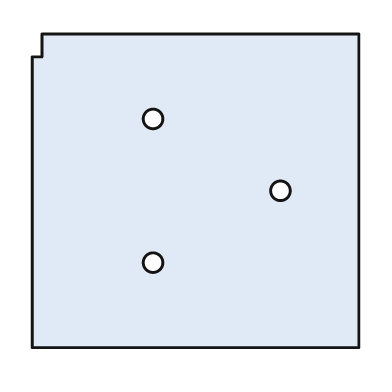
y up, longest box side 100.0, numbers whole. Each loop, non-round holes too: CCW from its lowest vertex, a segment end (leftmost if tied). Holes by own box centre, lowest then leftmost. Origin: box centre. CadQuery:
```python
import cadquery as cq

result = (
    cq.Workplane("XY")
    .moveTo(-50.0, -48.0)
    .lineTo(50.0, -48.0)
    .lineTo(50.0, 48.0)
    .lineTo(-47.0, 48.0)
    .lineTo(-47.0, 41.0)
    .lineTo(-50.0, 41.0)
    .close()
    .moveTo(-13.0, -22.0)
    .circle(3.0)
    .moveTo(26.0, 0.0)
    .circle(3.0)
    .moveTo(-13.0, 22.0)
    .circle(3.0)
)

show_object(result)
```